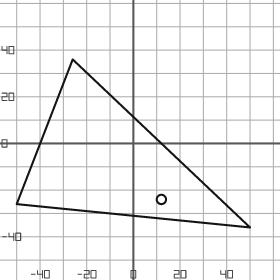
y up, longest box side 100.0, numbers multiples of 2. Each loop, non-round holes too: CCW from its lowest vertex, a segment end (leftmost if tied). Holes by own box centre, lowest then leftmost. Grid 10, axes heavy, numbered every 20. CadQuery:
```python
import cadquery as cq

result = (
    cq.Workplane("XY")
    .moveTo(50.0, -36.0)
    .lineTo(-26.0, 36.0)
    .lineTo(-50.0, -26.0)
    .close()
    .moveTo(12.0, -24.0)
    .circle(2.0)
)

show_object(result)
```